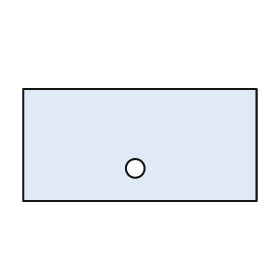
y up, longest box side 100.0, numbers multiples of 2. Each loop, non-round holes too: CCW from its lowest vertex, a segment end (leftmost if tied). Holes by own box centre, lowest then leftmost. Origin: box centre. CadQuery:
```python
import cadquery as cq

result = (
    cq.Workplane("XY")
    .moveTo(-50.0, -24.0)
    .lineTo(50.0, -24.0)
    .lineTo(50.0, 24.0)
    .lineTo(-50.0, 24.0)
    .close()
    .moveTo(-2.0, -10.0)
    .circle(4.0)
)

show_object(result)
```